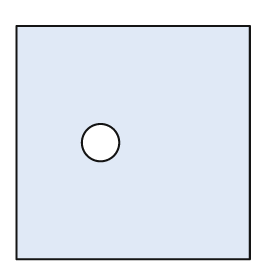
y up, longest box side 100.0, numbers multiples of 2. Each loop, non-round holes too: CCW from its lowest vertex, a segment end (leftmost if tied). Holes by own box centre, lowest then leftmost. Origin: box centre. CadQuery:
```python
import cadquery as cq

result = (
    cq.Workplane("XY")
    .moveTo(-50.0, -50.0)
    .lineTo(50.0, -50.0)
    .lineTo(50.0, 50.0)
    .lineTo(-50.0, 50.0)
    .close()
    .moveTo(-14.0, 0.0)
    .circle(8.0)
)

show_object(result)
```